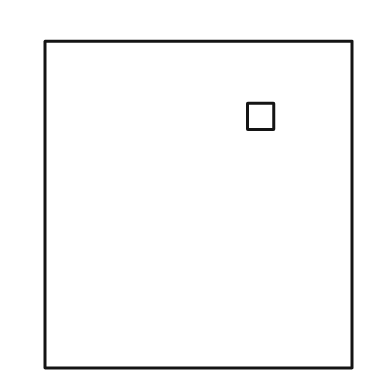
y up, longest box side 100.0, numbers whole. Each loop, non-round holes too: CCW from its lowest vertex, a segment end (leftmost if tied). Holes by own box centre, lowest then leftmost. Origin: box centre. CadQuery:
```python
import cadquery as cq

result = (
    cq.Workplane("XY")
    .moveTo(-47.0, -50.0)
    .lineTo(47.0, -50.0)
    .lineTo(47.0, 50.0)
    .lineTo(-47.0, 50.0)
    .close()
    .moveTo(15.0, 23.0)
    .lineTo(23.0, 23.0)
    .lineTo(23.0, 31.0)
    .lineTo(15.0, 31.0)
    .close()
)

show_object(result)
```